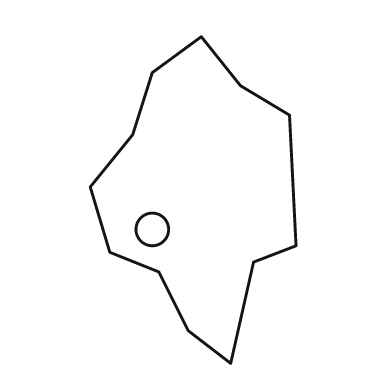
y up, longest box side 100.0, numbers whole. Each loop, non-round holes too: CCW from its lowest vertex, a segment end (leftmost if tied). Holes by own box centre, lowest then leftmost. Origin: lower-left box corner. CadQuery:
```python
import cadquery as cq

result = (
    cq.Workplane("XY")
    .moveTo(43.0, 0.0)
    .lineTo(50.0, 31.0)
    .lineTo(63.0, 36.0)
    .lineTo(61.0, 76.0)
    .lineTo(46.0, 85.0)
    .lineTo(34.0, 100.0)
    .lineTo(19.0, 89.0)
    .lineTo(13.0, 70.0)
    .lineTo(0.0, 54.0)
    .lineTo(6.0, 34.0)
    .lineTo(21.0, 28.0)
    .lineTo(30.0, 10.0)
    .close()
    .moveTo(19.0, 41.0)
    .circle(5.0)
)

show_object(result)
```